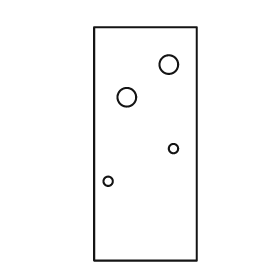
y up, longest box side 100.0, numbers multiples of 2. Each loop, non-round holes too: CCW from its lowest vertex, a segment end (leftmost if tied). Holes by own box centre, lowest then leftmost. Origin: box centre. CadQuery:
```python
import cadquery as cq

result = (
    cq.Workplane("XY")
    .moveTo(-22.0, -50.0)
    .lineTo(22.0, -50.0)
    .lineTo(22.0, 50.0)
    .lineTo(-22.0, 50.0)
    .close()
    .moveTo(-16.0, -16.0)
    .circle(2.0)
    .moveTo(12.0, -2.0)
    .circle(2.0)
    .moveTo(-8.0, 20.0)
    .circle(4.0)
    .moveTo(10.0, 34.0)
    .circle(4.0)
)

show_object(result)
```